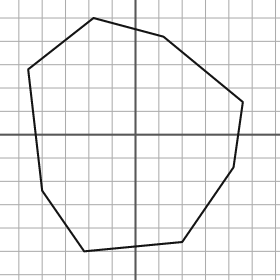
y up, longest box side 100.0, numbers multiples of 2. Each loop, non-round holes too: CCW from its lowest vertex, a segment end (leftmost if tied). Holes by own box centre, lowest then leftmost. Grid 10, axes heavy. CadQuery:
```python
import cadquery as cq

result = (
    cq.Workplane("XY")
    .moveTo(-22.0, -50.0)
    .lineTo(20.0, -46.0)
    .lineTo(42.0, -14.0)
    .lineTo(46.0, 14.0)
    .lineTo(12.0, 42.0)
    .lineTo(-18.0, 50.0)
    .lineTo(-46.0, 28.0)
    .lineTo(-40.0, -24.0)
    .close()
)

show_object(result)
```